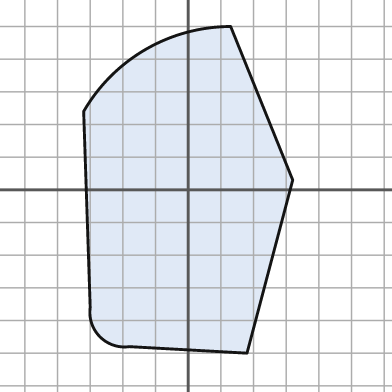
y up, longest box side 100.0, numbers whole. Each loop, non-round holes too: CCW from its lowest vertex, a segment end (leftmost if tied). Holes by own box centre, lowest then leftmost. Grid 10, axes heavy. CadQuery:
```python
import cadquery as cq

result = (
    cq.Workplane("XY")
    .moveTo(18.0, -50.0)
    .lineTo(32.0, 3.0)
    .lineTo(13.0, 50.0)
    .threePointArc((-13.0, 43.0), (-32.0, 24.0))
    .lineTo(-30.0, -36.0)
    .threePointArc((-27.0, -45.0), (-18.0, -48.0))
    .close()
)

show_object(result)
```